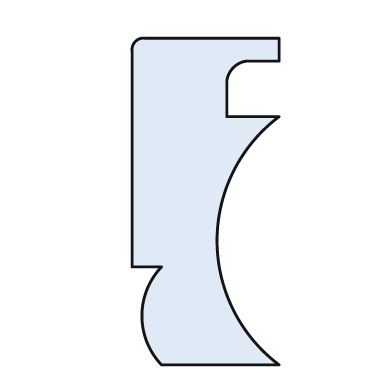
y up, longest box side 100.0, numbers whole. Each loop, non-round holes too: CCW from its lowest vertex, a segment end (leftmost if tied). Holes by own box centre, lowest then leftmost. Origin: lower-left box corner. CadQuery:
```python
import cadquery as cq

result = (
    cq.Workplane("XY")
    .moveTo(9.0, 0.0)
    .lineTo(45.0, 0.0)
    .threePointArc((26.0, 38.0), (45.0, 76.0))
    .lineTo(29.0, 76.0)
    .lineTo(29.0, 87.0)
    .threePointArc((31.0, 91.0), (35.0, 93.0))
    .lineTo(45.0, 93.0)
    .lineTo(45.0, 100.0)
    .lineTo(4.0, 100.0)
    .threePointArc((1.0, 99.0), (0.0, 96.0))
    .lineTo(0.0, 30.0)
    .lineTo(9.0, 30.0)
    .threePointArc((3.0, 15.0), (9.0, 0.0))
    .close()
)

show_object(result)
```